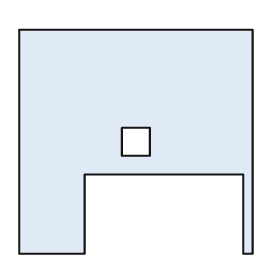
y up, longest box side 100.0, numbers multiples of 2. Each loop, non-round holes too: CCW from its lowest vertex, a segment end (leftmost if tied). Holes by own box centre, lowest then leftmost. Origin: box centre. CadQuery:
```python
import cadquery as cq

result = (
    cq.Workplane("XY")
    .moveTo(-50.0, -48.0)
    .lineTo(-22.0, -48.0)
    .lineTo(-22.0, -14.0)
    .lineTo(46.0, -14.0)
    .lineTo(46.0, -48.0)
    .lineTo(50.0, -48.0)
    .lineTo(50.0, 48.0)
    .lineTo(-50.0, 48.0)
    .close()
    .moveTo(-6.0, -6.0)
    .lineTo(6.0, -6.0)
    .lineTo(6.0, 6.0)
    .lineTo(-6.0, 6.0)
    .close()
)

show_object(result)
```